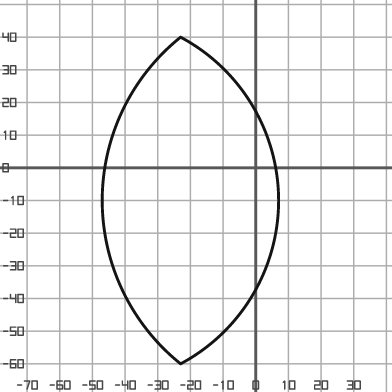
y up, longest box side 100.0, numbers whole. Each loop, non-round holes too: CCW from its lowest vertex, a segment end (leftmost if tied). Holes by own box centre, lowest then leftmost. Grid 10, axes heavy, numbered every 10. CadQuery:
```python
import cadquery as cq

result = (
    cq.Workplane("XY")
    .moveTo(-23.0, -60.0)
    .threePointArc((7.0, -10.0), (-23.0, 40.0))
    .threePointArc((-47.0, -10.0), (-23.0, -60.0))
    .close()
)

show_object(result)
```